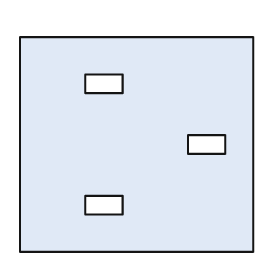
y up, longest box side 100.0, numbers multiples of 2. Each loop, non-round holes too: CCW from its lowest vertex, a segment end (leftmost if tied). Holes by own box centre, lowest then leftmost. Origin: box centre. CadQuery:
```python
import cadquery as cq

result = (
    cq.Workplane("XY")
    .moveTo(-50.0, -46.0)
    .lineTo(50.0, -46.0)
    .lineTo(50.0, 46.0)
    .lineTo(-50.0, 46.0)
    .close()
    .moveTo(-22.0, -30.0)
    .lineTo(-6.0, -30.0)
    .lineTo(-6.0, -22.0)
    .lineTo(-22.0, -22.0)
    .close()
    .moveTo(22.0, -4.0)
    .lineTo(38.0, -4.0)
    .lineTo(38.0, 4.0)
    .lineTo(22.0, 4.0)
    .close()
    .moveTo(-22.0, 22.0)
    .lineTo(-6.0, 22.0)
    .lineTo(-6.0, 30.0)
    .lineTo(-22.0, 30.0)
    .close()
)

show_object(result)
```